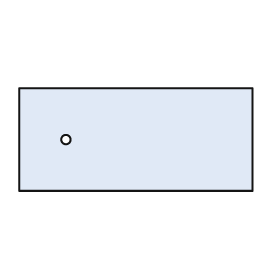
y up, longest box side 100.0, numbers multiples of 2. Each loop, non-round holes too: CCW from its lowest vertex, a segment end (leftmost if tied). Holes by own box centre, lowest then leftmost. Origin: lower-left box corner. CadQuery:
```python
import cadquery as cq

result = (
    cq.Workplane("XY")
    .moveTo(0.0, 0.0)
    .lineTo(100.0, 0.0)
    .lineTo(100.0, 44.0)
    .lineTo(0.0, 44.0)
    .close()
    .moveTo(20.0, 22.0)
    .circle(2.0)
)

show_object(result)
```